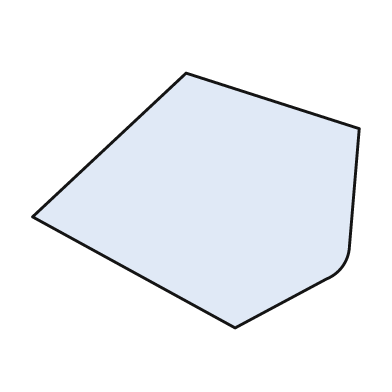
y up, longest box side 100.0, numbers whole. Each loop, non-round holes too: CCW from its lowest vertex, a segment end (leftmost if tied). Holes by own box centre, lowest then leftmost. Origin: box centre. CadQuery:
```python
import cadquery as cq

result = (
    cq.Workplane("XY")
    .moveTo(12.0, -39.0)
    .lineTo(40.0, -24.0)
    .threePointArc((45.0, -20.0), (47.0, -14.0))
    .lineTo(50.0, 22.0)
    .lineTo(-3.0, 39.0)
    .lineTo(-50.0, -5.0)
    .close()
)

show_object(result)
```